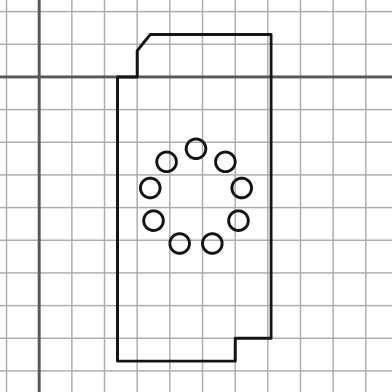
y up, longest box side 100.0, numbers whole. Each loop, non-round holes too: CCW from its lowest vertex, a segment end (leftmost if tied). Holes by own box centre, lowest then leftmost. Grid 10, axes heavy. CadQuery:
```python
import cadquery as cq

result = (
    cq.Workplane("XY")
    .moveTo(24.0, -87.0)
    .lineTo(60.0, -87.0)
    .lineTo(60.0, -80.0)
    .lineTo(71.0, -80.0)
    .lineTo(71.0, 13.0)
    .lineTo(34.0, 13.0)
    .lineTo(30.0, 8.0)
    .lineTo(30.0, 0.0)
    .lineTo(24.0, 0.0)
    .close()
    .moveTo(43.0, -51.0)
    .circle(3.0)
    .moveTo(53.0, -51.0)
    .circle(3.0)
    .moveTo(35.0, -44.0)
    .circle(3.0)
    .moveTo(61.0, -44.0)
    .circle(3.0)
    .moveTo(34.0, -34.0)
    .circle(3.0)
    .moveTo(62.0, -34.0)
    .circle(3.0)
    .moveTo(39.0, -26.0)
    .circle(3.0)
    .moveTo(57.0, -26.0)
    .circle(3.0)
    .moveTo(48.0, -22.0)
    .circle(3.0)
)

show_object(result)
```